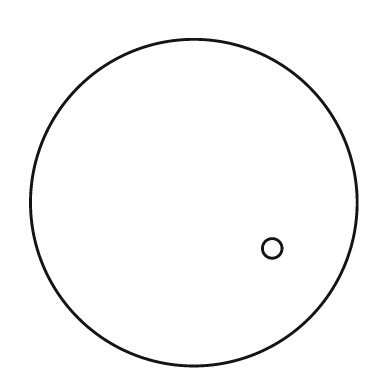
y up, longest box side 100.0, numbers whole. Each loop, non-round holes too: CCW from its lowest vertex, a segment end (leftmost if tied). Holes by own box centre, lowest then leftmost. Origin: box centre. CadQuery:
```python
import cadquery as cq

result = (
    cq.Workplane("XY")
    .moveTo(0.0, 0.0)
    .circle(50.0)
    .moveTo(24.0, -14.0)
    .circle(3.0)
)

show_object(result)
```